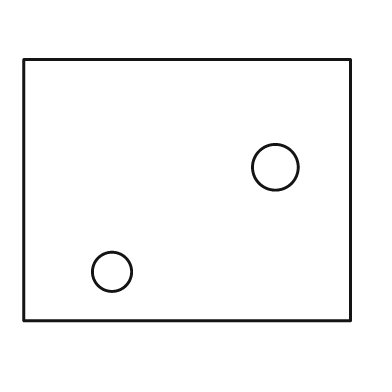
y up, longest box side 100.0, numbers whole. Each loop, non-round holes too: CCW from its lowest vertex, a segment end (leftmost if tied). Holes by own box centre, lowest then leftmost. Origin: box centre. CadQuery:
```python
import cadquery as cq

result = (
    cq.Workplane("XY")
    .moveTo(-50.0, -40.0)
    .lineTo(50.0, -40.0)
    .lineTo(50.0, 40.0)
    .lineTo(-50.0, 40.0)
    .close()
    .moveTo(-23.0, -25.0)
    .circle(6.0)
    .moveTo(27.0, 7.0)
    .circle(7.0)
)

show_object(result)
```